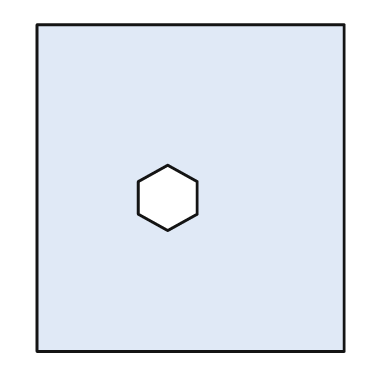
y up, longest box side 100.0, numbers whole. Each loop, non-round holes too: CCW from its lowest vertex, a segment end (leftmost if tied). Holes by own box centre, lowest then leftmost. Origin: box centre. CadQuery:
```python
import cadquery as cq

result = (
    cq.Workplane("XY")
    .moveTo(-47.0, -50.0)
    .lineTo(47.0, -50.0)
    .lineTo(47.0, 50.0)
    .lineTo(-47.0, 50.0)
    .close()
    .moveTo(-7.0, -13.0)
    .lineTo(2.0, -8.0)
    .lineTo(2.0, 2.0)
    .lineTo(-7.0, 7.0)
    .lineTo(-16.0, 2.0)
    .lineTo(-16.0, -8.0)
    .close()
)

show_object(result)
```